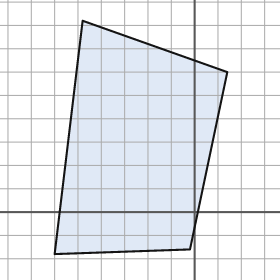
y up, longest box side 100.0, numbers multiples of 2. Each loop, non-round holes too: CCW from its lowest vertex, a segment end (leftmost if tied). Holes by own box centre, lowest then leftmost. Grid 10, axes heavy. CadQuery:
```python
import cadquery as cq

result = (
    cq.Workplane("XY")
    .moveTo(-60.0, -18.0)
    .lineTo(-2.0, -16.0)
    .lineTo(14.0, 60.0)
    .lineTo(-48.0, 82.0)
    .close()
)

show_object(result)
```